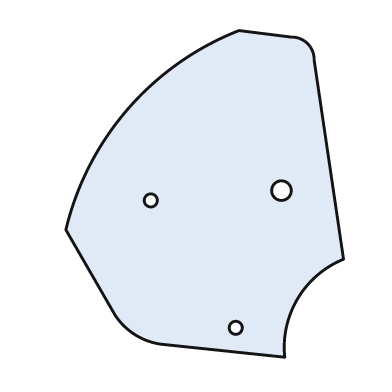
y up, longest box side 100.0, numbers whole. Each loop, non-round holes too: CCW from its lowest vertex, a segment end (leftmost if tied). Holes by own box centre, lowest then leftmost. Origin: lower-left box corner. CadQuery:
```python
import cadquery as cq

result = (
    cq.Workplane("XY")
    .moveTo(67.0, 0.0)
    .threePointArc((71.0, 18.0), (85.0, 30.0))
    .lineTo(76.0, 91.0)
    .threePointArc((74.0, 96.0), (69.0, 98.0))
    .lineTo(53.0, 100.0)
    .threePointArc((19.0, 76.0), (0.0, 39.0))
    .lineTo(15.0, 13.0)
    .threePointArc((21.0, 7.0), (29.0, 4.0))
    .close()
    .moveTo(52.0, 9.0)
    .circle(2.0)
    .moveTo(26.0, 48.0)
    .circle(2.0)
    .moveTo(66.0, 51.0)
    .circle(3.0)
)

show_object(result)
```